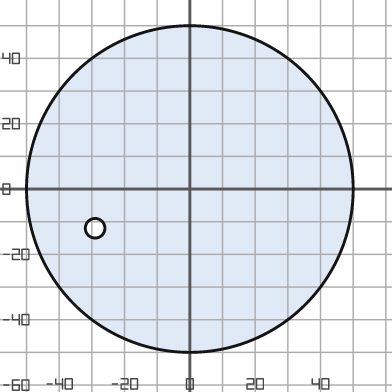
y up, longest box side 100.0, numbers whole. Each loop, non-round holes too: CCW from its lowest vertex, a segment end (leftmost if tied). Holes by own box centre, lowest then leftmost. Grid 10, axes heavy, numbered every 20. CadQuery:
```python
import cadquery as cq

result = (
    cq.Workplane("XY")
    .moveTo(0.0, 0.0)
    .circle(50.0)
    .moveTo(-29.0, -12.0)
    .circle(3.0)
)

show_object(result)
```